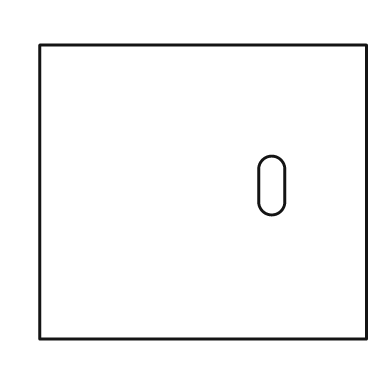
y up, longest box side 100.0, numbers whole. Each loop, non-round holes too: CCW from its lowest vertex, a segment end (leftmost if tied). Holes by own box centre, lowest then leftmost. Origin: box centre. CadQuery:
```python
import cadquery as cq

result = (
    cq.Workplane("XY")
    .moveTo(-50.0, -45.0)
    .lineTo(50.0, -45.0)
    .lineTo(50.0, 45.0)
    .lineTo(-50.0, 45.0)
    .close()
    .moveTo(17.0, -3.0)
    .threePointArc((21.0, -7.0), (25.0, -3.0))
    .lineTo(25.0, 7.0)
    .threePointArc((21.0, 11.0), (17.0, 7.0))
    .close()
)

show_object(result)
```